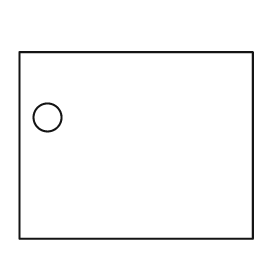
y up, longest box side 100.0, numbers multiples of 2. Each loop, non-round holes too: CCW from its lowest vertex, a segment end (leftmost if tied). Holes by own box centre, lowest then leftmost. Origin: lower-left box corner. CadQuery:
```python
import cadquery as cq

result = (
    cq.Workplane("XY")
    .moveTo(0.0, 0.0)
    .lineTo(100.0, 0.0)
    .lineTo(100.0, 80.0)
    .lineTo(0.0, 80.0)
    .close()
    .moveTo(12.0, 52.0)
    .circle(6.0)
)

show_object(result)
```